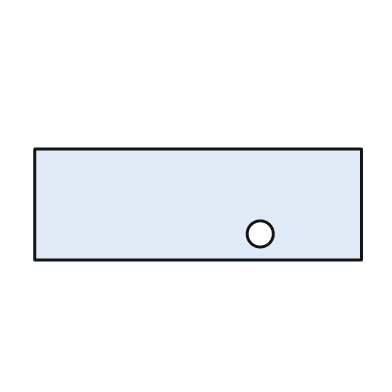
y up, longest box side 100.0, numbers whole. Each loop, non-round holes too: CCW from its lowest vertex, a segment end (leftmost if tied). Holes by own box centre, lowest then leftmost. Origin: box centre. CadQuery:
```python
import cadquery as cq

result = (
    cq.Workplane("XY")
    .moveTo(-50.0, -17.0)
    .lineTo(50.0, -17.0)
    .lineTo(50.0, 17.0)
    .lineTo(-50.0, 17.0)
    .close()
    .moveTo(19.0, -9.0)
    .circle(4.0)
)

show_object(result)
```